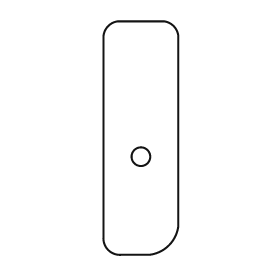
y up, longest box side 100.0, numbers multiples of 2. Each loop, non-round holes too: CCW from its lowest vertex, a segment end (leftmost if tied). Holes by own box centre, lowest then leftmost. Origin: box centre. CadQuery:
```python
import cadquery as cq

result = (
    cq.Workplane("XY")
    .moveTo(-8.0, -50.0)
    .lineTo(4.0, -50.0)
    .threePointArc((12.0, -46.0), (16.0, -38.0))
    .lineTo(16.0, 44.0)
    .threePointArc((14.0, 48.0), (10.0, 50.0))
    .lineTo(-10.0, 50.0)
    .threePointArc((-14.0, 48.0), (-16.0, 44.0))
    .lineTo(-16.0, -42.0)
    .threePointArc((-14.0, -48.0), (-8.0, -50.0))
    .close()
    .moveTo(0.0, -8.0)
    .circle(4.0)
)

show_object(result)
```